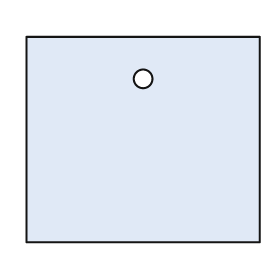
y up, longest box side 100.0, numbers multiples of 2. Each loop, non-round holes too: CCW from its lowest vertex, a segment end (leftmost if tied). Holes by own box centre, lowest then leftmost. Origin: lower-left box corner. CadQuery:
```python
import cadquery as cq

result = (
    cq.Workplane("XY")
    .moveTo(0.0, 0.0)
    .lineTo(100.0, 0.0)
    .lineTo(100.0, 88.0)
    .lineTo(0.0, 88.0)
    .close()
    .moveTo(50.0, 70.0)
    .circle(4.0)
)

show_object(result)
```